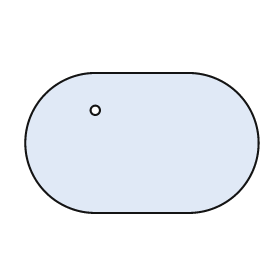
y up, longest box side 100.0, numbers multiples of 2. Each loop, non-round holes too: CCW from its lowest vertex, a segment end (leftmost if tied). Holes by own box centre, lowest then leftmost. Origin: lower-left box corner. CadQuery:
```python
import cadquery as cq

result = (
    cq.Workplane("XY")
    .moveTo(30.0, 0.0)
    .lineTo(70.0, 0.0)
    .threePointArc((100.0, 30.0), (70.0, 60.0))
    .lineTo(30.0, 60.0)
    .threePointArc((0.0, 30.0), (30.0, 0.0))
    .close()
    .moveTo(30.0, 44.0)
    .circle(2.0)
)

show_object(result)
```